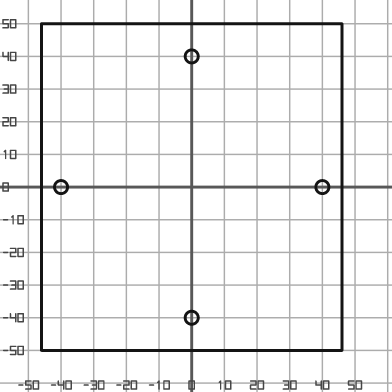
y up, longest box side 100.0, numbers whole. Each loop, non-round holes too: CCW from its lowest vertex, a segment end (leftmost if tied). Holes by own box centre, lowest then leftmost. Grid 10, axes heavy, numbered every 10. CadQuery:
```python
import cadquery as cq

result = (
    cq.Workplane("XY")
    .moveTo(-46.0, -50.0)
    .lineTo(46.0, -50.0)
    .lineTo(46.0, 50.0)
    .lineTo(-46.0, 50.0)
    .close()
    .moveTo(0.0, -40.0)
    .circle(2.0)
    .moveTo(-40.0, 0.0)
    .circle(2.0)
    .moveTo(40.0, 0.0)
    .circle(2.0)
    .moveTo(0.0, 40.0)
    .circle(2.0)
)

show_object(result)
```